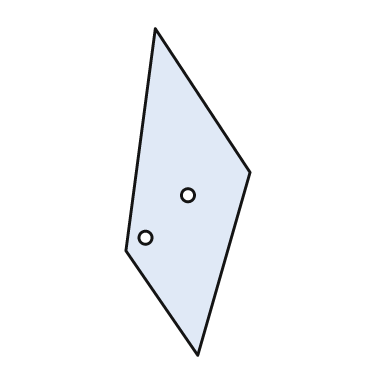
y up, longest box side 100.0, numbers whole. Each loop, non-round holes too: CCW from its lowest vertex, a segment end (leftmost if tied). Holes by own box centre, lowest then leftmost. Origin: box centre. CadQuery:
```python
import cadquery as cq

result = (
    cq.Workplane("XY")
    .moveTo(3.0, -50.0)
    .lineTo(19.0, 6.0)
    .lineTo(-10.0, 50.0)
    .lineTo(-19.0, -18.0)
    .close()
    .moveTo(-13.0, -14.0)
    .circle(2.0)
    .moveTo(0.0, -1.0)
    .circle(2.0)
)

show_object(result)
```